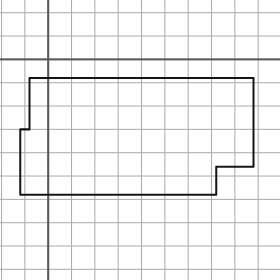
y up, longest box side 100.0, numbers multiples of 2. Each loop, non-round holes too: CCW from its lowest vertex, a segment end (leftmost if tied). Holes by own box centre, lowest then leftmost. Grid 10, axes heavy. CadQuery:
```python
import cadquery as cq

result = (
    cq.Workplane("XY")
    .moveTo(-12.0, -58.0)
    .lineTo(72.0, -58.0)
    .lineTo(72.0, -46.0)
    .lineTo(88.0, -46.0)
    .lineTo(88.0, -8.0)
    .lineTo(-8.0, -8.0)
    .lineTo(-8.0, -30.0)
    .lineTo(-12.0, -30.0)
    .close()
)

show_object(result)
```